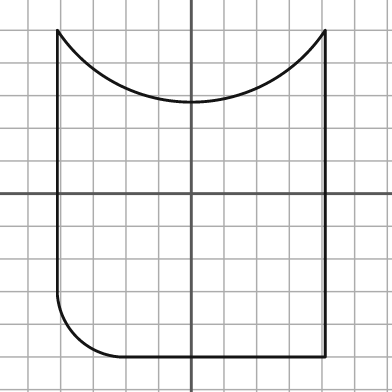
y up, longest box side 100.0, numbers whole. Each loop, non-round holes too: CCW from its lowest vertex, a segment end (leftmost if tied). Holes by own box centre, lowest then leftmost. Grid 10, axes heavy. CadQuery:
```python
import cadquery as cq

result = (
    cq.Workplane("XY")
    .moveTo(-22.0, -50.0)
    .lineTo(41.0, -50.0)
    .lineTo(41.0, 50.0)
    .threePointArc((0.0, 28.0), (-41.0, 50.0))
    .lineTo(-41.0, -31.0)
    .threePointArc((-35.0, -44.0), (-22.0, -50.0))
    .close()
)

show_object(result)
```